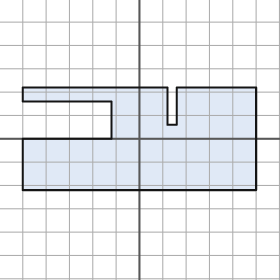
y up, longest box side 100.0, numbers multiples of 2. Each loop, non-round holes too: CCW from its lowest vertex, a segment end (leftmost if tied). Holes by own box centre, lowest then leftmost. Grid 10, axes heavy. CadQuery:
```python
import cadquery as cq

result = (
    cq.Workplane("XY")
    .moveTo(-50.0, -22.0)
    .lineTo(50.0, -22.0)
    .lineTo(50.0, 22.0)
    .lineTo(16.0, 22.0)
    .lineTo(16.0, 6.0)
    .lineTo(12.0, 6.0)
    .lineTo(12.0, 22.0)
    .lineTo(-50.0, 22.0)
    .lineTo(-50.0, 16.0)
    .lineTo(-12.0, 16.0)
    .lineTo(-12.0, 0.0)
    .lineTo(-50.0, 0.0)
    .close()
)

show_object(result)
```